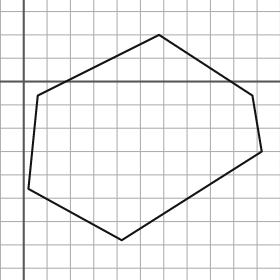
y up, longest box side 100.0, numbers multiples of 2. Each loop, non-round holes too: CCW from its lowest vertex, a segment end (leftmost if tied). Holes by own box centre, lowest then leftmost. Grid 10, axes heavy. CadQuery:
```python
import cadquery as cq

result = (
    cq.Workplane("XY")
    .moveTo(42.0, -68.0)
    .lineTo(102.0, -30.0)
    .lineTo(98.0, -6.0)
    .lineTo(58.0, 20.0)
    .lineTo(6.0, -6.0)
    .lineTo(2.0, -46.0)
    .close()
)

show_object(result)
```